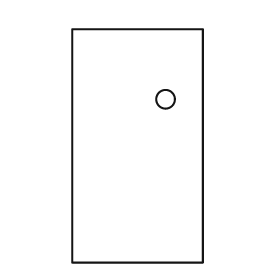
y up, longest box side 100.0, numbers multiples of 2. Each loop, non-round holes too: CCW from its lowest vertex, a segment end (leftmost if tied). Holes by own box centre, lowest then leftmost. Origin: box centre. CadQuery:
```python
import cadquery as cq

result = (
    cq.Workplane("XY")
    .moveTo(-28.0, -50.0)
    .lineTo(28.0, -50.0)
    .lineTo(28.0, 50.0)
    .lineTo(-28.0, 50.0)
    .close()
    .moveTo(12.0, 20.0)
    .circle(4.0)
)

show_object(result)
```